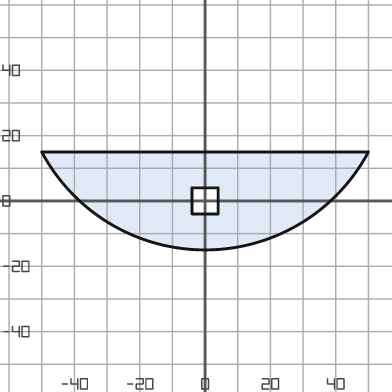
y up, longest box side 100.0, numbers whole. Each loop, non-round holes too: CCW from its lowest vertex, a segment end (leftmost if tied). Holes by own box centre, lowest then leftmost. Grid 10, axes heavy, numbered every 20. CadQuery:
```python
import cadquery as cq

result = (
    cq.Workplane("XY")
    .moveTo(-50.0, 15.0)
    .threePointArc((0.0, -15.0), (50.0, 15.0))
    .close()
    .moveTo(-4.0, -4.0)
    .lineTo(4.0, -4.0)
    .lineTo(4.0, 4.0)
    .lineTo(-4.0, 4.0)
    .close()
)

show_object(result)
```